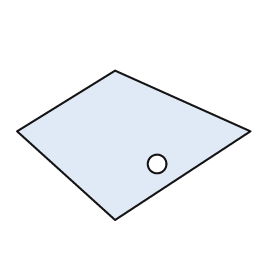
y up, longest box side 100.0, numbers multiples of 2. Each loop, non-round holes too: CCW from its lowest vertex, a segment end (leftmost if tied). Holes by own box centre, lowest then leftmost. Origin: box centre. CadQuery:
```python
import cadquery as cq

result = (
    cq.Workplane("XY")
    .moveTo(-8.0, -32.0)
    .lineTo(50.0, 6.0)
    .lineTo(-8.0, 32.0)
    .lineTo(-50.0, 6.0)
    .close()
    .moveTo(10.0, -8.0)
    .circle(4.0)
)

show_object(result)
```